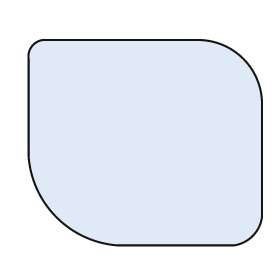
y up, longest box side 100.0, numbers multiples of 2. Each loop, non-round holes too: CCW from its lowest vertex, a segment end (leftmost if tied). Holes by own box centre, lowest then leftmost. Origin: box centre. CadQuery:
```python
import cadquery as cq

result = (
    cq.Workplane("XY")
    .moveTo(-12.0, -44.0)
    .lineTo(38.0, -44.0)
    .threePointArc((46.0, -40.0), (50.0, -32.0))
    .lineTo(50.0, 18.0)
    .threePointArc((42.0, 36.0), (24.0, 44.0))
    .lineTo(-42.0, 44.0)
    .threePointArc((-48.0, 42.0), (-50.0, 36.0))
    .lineTo(-50.0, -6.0)
    .threePointArc((-38.0, -32.0), (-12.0, -44.0))
    .close()
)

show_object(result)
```